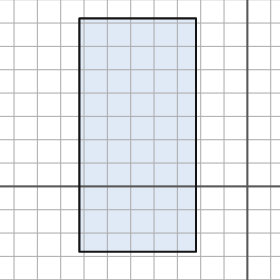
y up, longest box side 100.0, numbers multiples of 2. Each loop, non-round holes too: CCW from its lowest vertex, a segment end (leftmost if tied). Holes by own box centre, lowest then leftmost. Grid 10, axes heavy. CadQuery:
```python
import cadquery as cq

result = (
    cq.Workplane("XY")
    .moveTo(-72.0, -28.0)
    .lineTo(-22.0, -28.0)
    .lineTo(-22.0, 72.0)
    .lineTo(-72.0, 72.0)
    .close()
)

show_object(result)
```